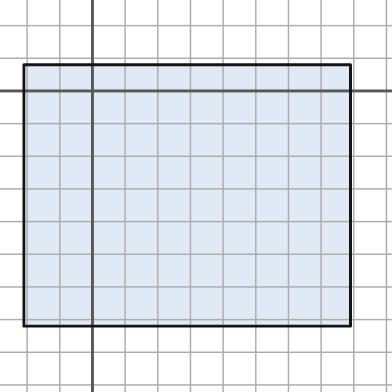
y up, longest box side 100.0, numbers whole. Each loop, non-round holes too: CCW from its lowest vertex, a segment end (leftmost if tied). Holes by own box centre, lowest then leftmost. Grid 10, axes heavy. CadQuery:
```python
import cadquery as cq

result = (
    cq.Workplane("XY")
    .moveTo(-21.0, -72.0)
    .lineTo(79.0, -72.0)
    .lineTo(79.0, 8.0)
    .lineTo(-21.0, 8.0)
    .close()
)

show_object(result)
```